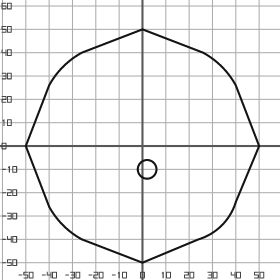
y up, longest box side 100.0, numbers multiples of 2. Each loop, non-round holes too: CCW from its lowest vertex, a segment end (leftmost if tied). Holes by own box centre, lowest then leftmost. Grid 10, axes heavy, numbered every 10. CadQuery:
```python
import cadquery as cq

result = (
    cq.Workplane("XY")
    .moveTo(0.0, -50.0)
    .lineTo(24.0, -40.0)
    .threePointArc((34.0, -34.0), (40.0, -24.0))
    .lineTo(50.0, 0.0)
    .lineTo(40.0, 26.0)
    .threePointArc((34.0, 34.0), (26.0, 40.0))
    .lineTo(0.0, 50.0)
    .lineTo(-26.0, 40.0)
    .threePointArc((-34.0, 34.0), (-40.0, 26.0))
    .lineTo(-50.0, 0.0)
    .lineTo(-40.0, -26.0)
    .threePointArc((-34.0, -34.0), (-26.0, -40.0))
    .close()
    .moveTo(2.0, -10.0)
    .circle(4.0)
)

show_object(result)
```